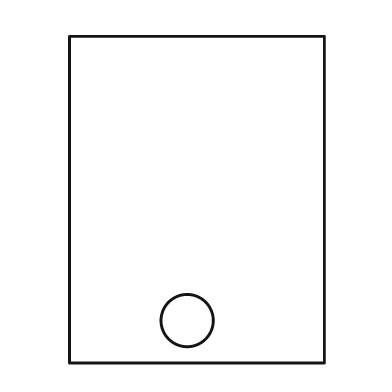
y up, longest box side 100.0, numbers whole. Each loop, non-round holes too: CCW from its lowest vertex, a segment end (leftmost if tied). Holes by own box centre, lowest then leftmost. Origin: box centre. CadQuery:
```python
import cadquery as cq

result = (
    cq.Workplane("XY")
    .moveTo(-39.0, -50.0)
    .lineTo(39.0, -50.0)
    .lineTo(39.0, 50.0)
    .lineTo(-39.0, 50.0)
    .close()
    .moveTo(-3.0, -37.0)
    .circle(8.0)
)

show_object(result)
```